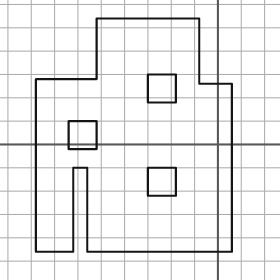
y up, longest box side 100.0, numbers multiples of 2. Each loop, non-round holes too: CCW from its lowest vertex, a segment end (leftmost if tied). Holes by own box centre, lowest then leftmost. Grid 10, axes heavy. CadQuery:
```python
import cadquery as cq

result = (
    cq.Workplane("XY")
    .moveTo(-78.0, -46.0)
    .lineTo(-62.0, -46.0)
    .lineTo(-62.0, -10.0)
    .lineTo(-56.0, -10.0)
    .lineTo(-56.0, -46.0)
    .lineTo(6.0, -46.0)
    .lineTo(6.0, 26.0)
    .lineTo(-8.0, 26.0)
    .lineTo(-8.0, 54.0)
    .lineTo(-52.0, 54.0)
    .lineTo(-52.0, 28.0)
    .lineTo(-78.0, 28.0)
    .close()
    .moveTo(-30.0, -22.0)
    .lineTo(-18.0, -22.0)
    .lineTo(-18.0, -10.0)
    .lineTo(-30.0, -10.0)
    .close()
    .moveTo(-64.0, -2.0)
    .lineTo(-52.0, -2.0)
    .lineTo(-52.0, 10.0)
    .lineTo(-64.0, 10.0)
    .close()
    .moveTo(-30.0, 18.0)
    .lineTo(-18.0, 18.0)
    .lineTo(-18.0, 30.0)
    .lineTo(-30.0, 30.0)
    .close()
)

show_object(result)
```